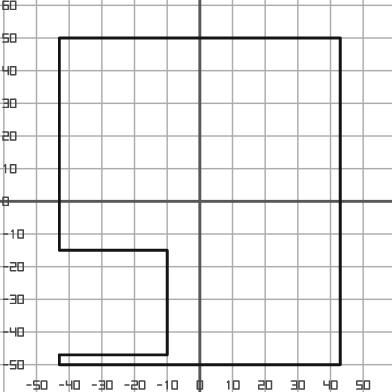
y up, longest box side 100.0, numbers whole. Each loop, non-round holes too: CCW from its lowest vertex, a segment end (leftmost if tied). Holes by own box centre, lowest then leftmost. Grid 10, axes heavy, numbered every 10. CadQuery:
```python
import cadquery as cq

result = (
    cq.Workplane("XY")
    .moveTo(-43.0, -50.0)
    .lineTo(43.0, -50.0)
    .lineTo(43.0, 50.0)
    .lineTo(-43.0, 50.0)
    .lineTo(-43.0, -15.0)
    .lineTo(-10.0, -15.0)
    .lineTo(-10.0, -47.0)
    .lineTo(-43.0, -47.0)
    .close()
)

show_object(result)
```